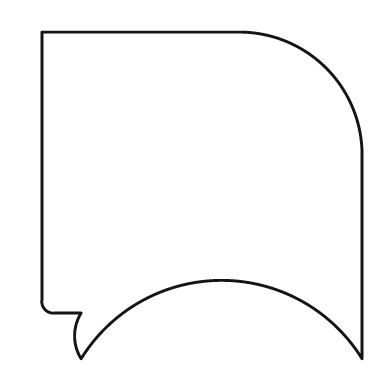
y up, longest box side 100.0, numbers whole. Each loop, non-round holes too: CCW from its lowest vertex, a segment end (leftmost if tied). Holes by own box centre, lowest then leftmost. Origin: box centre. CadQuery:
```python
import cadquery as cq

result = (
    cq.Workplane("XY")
    .moveTo(-37.0, -50.0)
    .threePointArc((6.0, -26.0), (49.0, -50.0))
    .lineTo(49.0, 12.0)
    .threePointArc((38.0, 39.0), (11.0, 50.0))
    .lineTo(-49.0, 50.0)
    .lineTo(-49.0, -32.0)
    .threePointArc((-48.0, -35.0), (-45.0, -36.0))
    .lineTo(-37.0, -36.0)
    .threePointArc((-39.0, -43.0), (-37.0, -50.0))
    .close()
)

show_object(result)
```